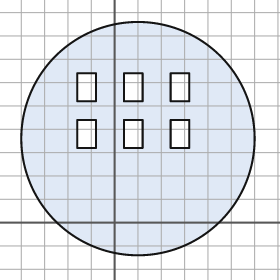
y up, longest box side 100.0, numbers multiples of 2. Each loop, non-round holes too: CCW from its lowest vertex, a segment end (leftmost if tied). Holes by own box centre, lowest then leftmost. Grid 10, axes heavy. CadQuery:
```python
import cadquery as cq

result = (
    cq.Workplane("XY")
    .moveTo(10.0, 36.0)
    .circle(50.0)
    .moveTo(-16.0, 32.0)
    .lineTo(-8.0, 32.0)
    .lineTo(-8.0, 44.0)
    .lineTo(-16.0, 44.0)
    .close()
    .moveTo(4.0, 32.0)
    .lineTo(12.0, 32.0)
    .lineTo(12.0, 44.0)
    .lineTo(4.0, 44.0)
    .close()
    .moveTo(24.0, 32.0)
    .lineTo(32.0, 32.0)
    .lineTo(32.0, 44.0)
    .lineTo(24.0, 44.0)
    .close()
    .moveTo(-16.0, 52.0)
    .lineTo(-8.0, 52.0)
    .lineTo(-8.0, 64.0)
    .lineTo(-16.0, 64.0)
    .close()
    .moveTo(4.0, 52.0)
    .lineTo(12.0, 52.0)
    .lineTo(12.0, 64.0)
    .lineTo(4.0, 64.0)
    .close()
    .moveTo(24.0, 52.0)
    .lineTo(32.0, 52.0)
    .lineTo(32.0, 64.0)
    .lineTo(24.0, 64.0)
    .close()
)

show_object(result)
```